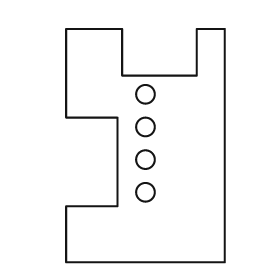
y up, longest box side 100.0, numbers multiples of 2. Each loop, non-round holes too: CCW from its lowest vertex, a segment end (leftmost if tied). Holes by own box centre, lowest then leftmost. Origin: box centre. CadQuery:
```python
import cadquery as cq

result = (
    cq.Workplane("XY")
    .moveTo(-34.0, -50.0)
    .lineTo(34.0, -50.0)
    .lineTo(34.0, 50.0)
    .lineTo(22.0, 50.0)
    .lineTo(22.0, 30.0)
    .lineTo(-10.0, 30.0)
    .lineTo(-10.0, 50.0)
    .lineTo(-34.0, 50.0)
    .lineTo(-34.0, 12.0)
    .lineTo(-12.0, 12.0)
    .lineTo(-12.0, -26.0)
    .lineTo(-34.0, -26.0)
    .close()
    .moveTo(0.0, -20.0)
    .circle(4.0)
    .moveTo(0.0, -6.0)
    .circle(4.0)
    .moveTo(0.0, 8.0)
    .circle(4.0)
    .moveTo(0.0, 22.0)
    .circle(4.0)
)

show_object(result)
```